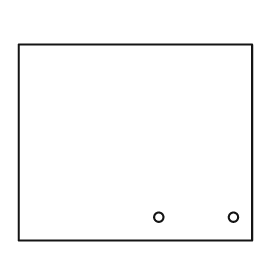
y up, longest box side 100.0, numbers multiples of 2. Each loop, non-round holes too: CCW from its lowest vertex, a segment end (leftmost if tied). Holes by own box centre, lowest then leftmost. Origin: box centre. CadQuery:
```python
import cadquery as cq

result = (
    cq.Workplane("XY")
    .moveTo(-50.0, -42.0)
    .lineTo(50.0, -42.0)
    .lineTo(50.0, 42.0)
    .lineTo(-50.0, 42.0)
    .close()
    .moveTo(10.0, -32.0)
    .circle(2.0)
    .moveTo(42.0, -32.0)
    .circle(2.0)
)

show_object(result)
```